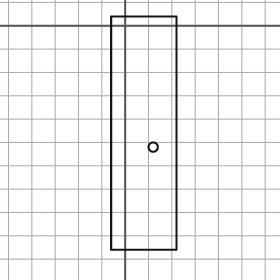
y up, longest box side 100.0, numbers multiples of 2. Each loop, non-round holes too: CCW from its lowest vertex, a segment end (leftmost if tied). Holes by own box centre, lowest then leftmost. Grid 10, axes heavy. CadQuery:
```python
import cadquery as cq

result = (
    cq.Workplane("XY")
    .moveTo(-6.0, -96.0)
    .lineTo(22.0, -96.0)
    .lineTo(22.0, 4.0)
    .lineTo(-6.0, 4.0)
    .close()
    .moveTo(12.0, -52.0)
    .circle(2.0)
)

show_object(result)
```